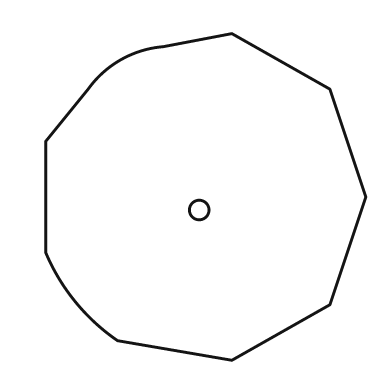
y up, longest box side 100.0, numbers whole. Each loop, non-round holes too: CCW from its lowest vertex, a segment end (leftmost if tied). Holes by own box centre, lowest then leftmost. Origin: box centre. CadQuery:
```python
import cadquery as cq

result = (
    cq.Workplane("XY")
    .moveTo(8.0, -50.0)
    .lineTo(38.0, -33.0)
    .lineTo(49.0, 0.0)
    .lineTo(38.0, 33.0)
    .lineTo(8.0, 50.0)
    .lineTo(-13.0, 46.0)
    .threePointArc((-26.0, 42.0), (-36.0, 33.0))
    .lineTo(-49.0, 17.0)
    .lineTo(-49.0, -17.0)
    .threePointArc((-40.0, -32.0), (-27.0, -44.0))
    .close()
    .moveTo(-2.0, -4.0)
    .circle(3.0)
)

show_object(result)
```